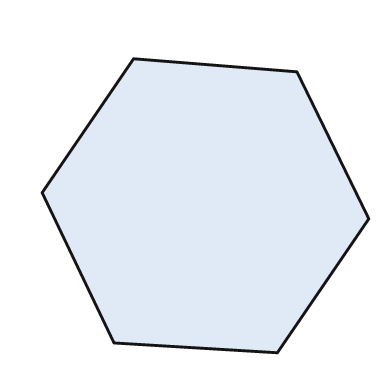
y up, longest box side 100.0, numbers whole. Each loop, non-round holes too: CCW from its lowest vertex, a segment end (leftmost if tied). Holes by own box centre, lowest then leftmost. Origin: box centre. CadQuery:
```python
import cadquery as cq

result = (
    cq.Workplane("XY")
    .moveTo(22.0, -45.0)
    .lineTo(50.0, -4.0)
    .lineTo(28.0, 41.0)
    .lineTo(-22.0, 45.0)
    .lineTo(-50.0, 4.0)
    .lineTo(-28.0, -42.0)
    .close()
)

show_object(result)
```